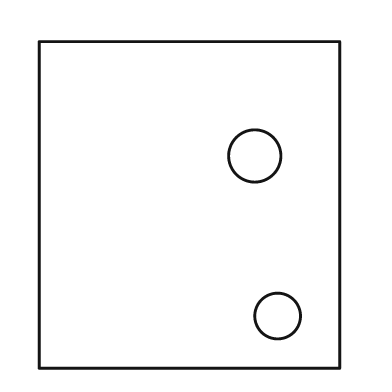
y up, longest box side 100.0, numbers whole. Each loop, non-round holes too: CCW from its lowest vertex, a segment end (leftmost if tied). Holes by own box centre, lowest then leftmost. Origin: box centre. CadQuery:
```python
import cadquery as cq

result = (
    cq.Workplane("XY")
    .moveTo(-46.0, -50.0)
    .lineTo(46.0, -50.0)
    .lineTo(46.0, 50.0)
    .lineTo(-46.0, 50.0)
    .close()
    .moveTo(27.0, -34.0)
    .circle(7.0)
    .moveTo(20.0, 15.0)
    .circle(8.0)
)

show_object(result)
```